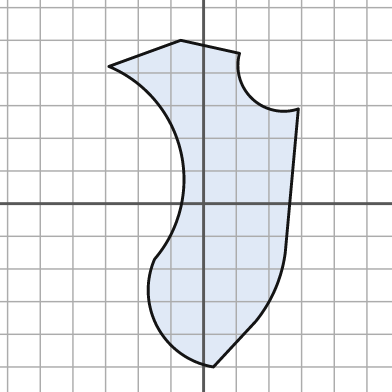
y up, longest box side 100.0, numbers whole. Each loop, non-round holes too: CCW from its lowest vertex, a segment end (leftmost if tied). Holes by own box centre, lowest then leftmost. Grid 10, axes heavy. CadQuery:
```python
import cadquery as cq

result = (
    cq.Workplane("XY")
    .moveTo(3.0, -50.0)
    .lineTo(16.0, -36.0)
    .threePointArc((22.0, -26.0), (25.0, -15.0))
    .lineTo(29.0, 29.0)
    .threePointArc((15.0, 32.0), (11.0, 46.0))
    .lineTo(-7.0, 50.0)
    .lineTo(-29.0, 42.0)
    .threePointArc((-7.0, 16.0), (-15.0, -17.0))
    .threePointArc((-14.0, -38.0), (3.0, -50.0))
    .close()
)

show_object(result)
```